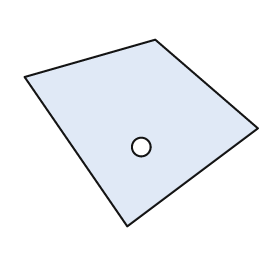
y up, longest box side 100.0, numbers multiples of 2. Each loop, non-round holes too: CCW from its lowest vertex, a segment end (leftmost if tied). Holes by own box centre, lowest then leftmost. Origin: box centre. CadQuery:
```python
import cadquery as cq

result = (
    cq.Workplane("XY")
    .moveTo(-6.0, -40.0)
    .lineTo(50.0, 2.0)
    .lineTo(6.0, 40.0)
    .lineTo(-50.0, 24.0)
    .close()
    .moveTo(0.0, -6.0)
    .circle(4.0)
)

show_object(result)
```